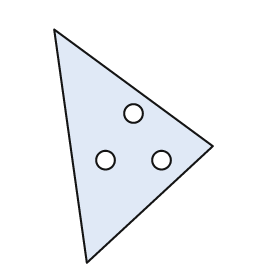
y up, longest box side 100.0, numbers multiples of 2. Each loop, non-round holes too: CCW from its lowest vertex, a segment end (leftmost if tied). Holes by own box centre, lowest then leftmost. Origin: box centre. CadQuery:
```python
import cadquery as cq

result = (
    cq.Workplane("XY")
    .moveTo(-20.0, -50.0)
    .lineTo(34.0, 0.0)
    .lineTo(-34.0, 50.0)
    .close()
    .moveTo(-12.0, -6.0)
    .circle(4.0)
    .moveTo(12.0, -6.0)
    .circle(4.0)
    .moveTo(0.0, 14.0)
    .circle(4.0)
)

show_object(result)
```